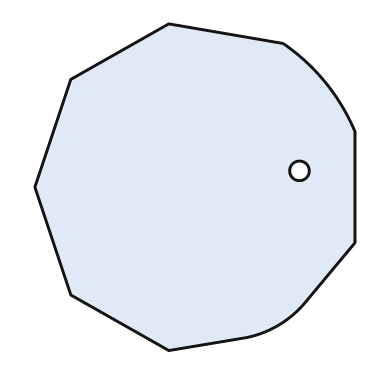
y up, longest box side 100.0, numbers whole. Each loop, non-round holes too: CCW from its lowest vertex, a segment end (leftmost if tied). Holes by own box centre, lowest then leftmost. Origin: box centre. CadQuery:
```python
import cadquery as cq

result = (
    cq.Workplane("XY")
    .moveTo(-8.0, -50.0)
    .lineTo(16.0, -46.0)
    .threePointArc((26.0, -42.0), (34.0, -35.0))
    .lineTo(49.0, -17.0)
    .lineTo(49.0, 17.0)
    .threePointArc((40.0, 32.0), (27.0, 44.0))
    .lineTo(-8.0, 50.0)
    .lineTo(-38.0, 33.0)
    .lineTo(-49.0, 0.0)
    .lineTo(-38.0, -33.0)
    .close()
    .moveTo(32.0, 5.0)
    .circle(3.0)
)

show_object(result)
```